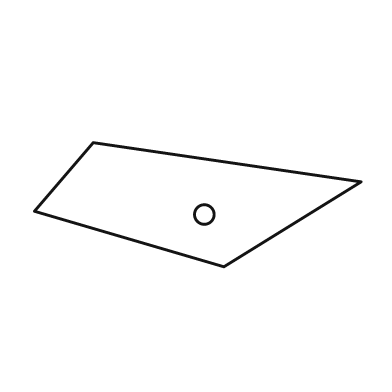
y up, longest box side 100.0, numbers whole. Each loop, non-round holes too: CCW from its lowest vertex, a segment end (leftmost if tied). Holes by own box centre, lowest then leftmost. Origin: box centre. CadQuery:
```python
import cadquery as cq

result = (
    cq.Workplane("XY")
    .moveTo(8.0, -19.0)
    .lineTo(50.0, 7.0)
    .lineTo(-32.0, 19.0)
    .lineTo(-50.0, -2.0)
    .close()
    .moveTo(2.0, -3.0)
    .circle(3.0)
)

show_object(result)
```